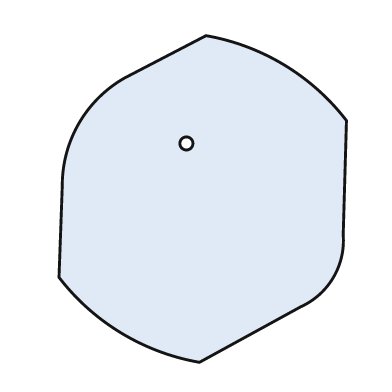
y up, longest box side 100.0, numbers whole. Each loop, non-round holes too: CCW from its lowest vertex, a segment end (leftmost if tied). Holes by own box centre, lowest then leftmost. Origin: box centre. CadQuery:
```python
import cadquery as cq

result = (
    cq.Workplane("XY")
    .moveTo(-1.0, -50.0)
    .lineTo(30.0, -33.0)
    .threePointArc((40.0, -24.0), (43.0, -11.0))
    .lineTo(44.0, 24.0)
    .threePointArc((25.0, 41.0), (1.0, 50.0))
    .lineTo(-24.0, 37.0)
    .threePointArc((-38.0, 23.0), (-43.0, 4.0))
    .lineTo(-44.0, -24.0)
    .threePointArc((-25.0, -41.0), (-1.0, -50.0))
    .close()
    .moveTo(-5.0, 17.0)
    .circle(2.0)
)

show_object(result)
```